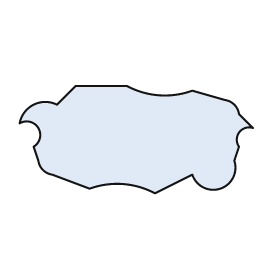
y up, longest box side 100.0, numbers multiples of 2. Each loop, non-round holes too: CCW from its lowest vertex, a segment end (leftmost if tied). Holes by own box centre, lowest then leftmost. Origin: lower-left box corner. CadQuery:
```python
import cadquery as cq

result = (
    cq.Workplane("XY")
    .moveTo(58.0, 0.0)
    .lineTo(74.0, 8.0)
    .threePointArc((86.0, 2.0), (92.0, 14.0))
    .lineTo(94.0, 20.0)
    .threePointArc((94.0, 26.0), (100.0, 28.0))
    .lineTo(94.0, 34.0)
    .threePointArc((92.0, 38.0), (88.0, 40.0))
    .lineTo(74.0, 44.0)
    .threePointArc((60.0, 42.0), (46.0, 46.0))
    .lineTo(24.0, 46.0)
    .lineTo(16.0, 38.0)
    .threePointArc((6.0, 38.0), (0.0, 30.0))
    .threePointArc((8.0, 28.0), (6.0, 20.0))
    .lineTo(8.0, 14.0)
    .threePointArc((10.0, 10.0), (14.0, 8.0))
    .lineTo(30.0, 2.0)
    .threePointArc((44.0, 4.0), (58.0, 0.0))
    .close()
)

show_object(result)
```